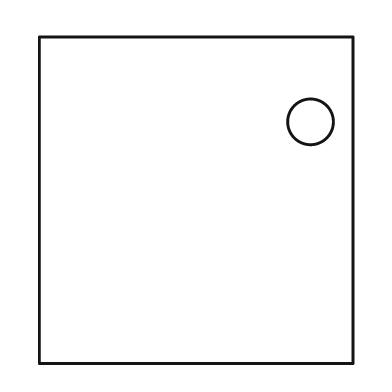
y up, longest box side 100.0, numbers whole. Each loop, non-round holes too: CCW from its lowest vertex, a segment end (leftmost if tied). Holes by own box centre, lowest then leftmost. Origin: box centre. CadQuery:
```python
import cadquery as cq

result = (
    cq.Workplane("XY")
    .moveTo(-48.0, -50.0)
    .lineTo(48.0, -50.0)
    .lineTo(48.0, 50.0)
    .lineTo(-48.0, 50.0)
    .close()
    .moveTo(35.0, 24.0)
    .circle(7.0)
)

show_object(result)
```